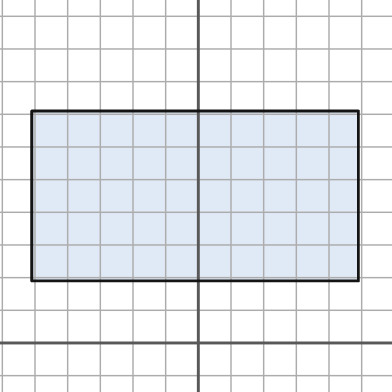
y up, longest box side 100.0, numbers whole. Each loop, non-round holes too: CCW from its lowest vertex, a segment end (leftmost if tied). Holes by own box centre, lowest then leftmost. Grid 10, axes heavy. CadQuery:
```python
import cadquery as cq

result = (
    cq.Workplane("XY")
    .moveTo(-51.0, 19.0)
    .lineTo(49.0, 19.0)
    .lineTo(49.0, 71.0)
    .lineTo(-51.0, 71.0)
    .close()
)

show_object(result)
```